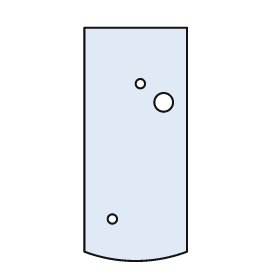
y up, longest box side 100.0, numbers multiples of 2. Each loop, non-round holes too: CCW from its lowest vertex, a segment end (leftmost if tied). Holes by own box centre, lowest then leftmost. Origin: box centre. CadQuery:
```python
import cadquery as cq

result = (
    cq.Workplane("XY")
    .moveTo(-22.0, -46.0)
    .threePointArc((0.0, -50.0), (22.0, -46.0))
    .lineTo(22.0, 50.0)
    .lineTo(-22.0, 50.0)
    .close()
    .moveTo(-10.0, -32.0)
    .circle(2.0)
    .moveTo(12.0, 18.0)
    .circle(4.0)
    .moveTo(2.0, 26.0)
    .circle(2.0)
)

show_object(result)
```